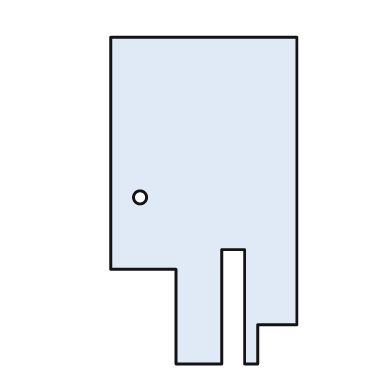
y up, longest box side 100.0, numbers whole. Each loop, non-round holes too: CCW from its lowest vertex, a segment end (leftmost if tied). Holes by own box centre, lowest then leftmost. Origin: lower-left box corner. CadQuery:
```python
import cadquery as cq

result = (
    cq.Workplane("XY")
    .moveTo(20.0, 0.0)
    .lineTo(34.0, 0.0)
    .lineTo(34.0, 35.0)
    .lineTo(41.0, 35.0)
    .lineTo(41.0, 0.0)
    .lineTo(45.0, 0.0)
    .lineTo(45.0, 12.0)
    .lineTo(57.0, 12.0)
    .lineTo(57.0, 100.0)
    .lineTo(0.0, 100.0)
    .lineTo(0.0, 29.0)
    .lineTo(20.0, 29.0)
    .close()
    .moveTo(9.0, 51.0)
    .circle(2.0)
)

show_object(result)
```